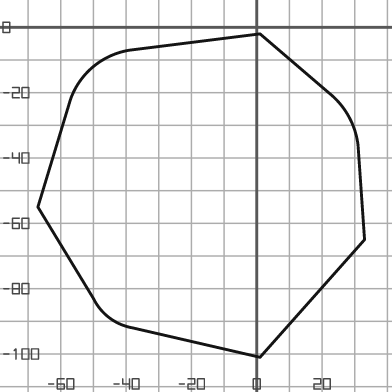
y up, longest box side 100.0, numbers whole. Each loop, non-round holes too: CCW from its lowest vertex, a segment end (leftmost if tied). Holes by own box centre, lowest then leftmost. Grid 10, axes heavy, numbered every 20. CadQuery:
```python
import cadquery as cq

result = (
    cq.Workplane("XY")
    .moveTo(1.0, -101.0)
    .lineTo(33.0, -65.0)
    .lineTo(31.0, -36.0)
    .threePointArc((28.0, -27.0), (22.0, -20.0))
    .lineTo(1.0, -2.0)
    .lineTo(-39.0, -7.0)
    .threePointArc((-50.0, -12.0), (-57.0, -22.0))
    .lineTo(-67.0, -55.0)
    .lineTo(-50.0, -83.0)
    .threePointArc((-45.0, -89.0), (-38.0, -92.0))
    .close()
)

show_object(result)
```